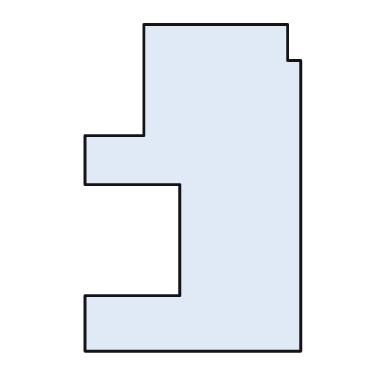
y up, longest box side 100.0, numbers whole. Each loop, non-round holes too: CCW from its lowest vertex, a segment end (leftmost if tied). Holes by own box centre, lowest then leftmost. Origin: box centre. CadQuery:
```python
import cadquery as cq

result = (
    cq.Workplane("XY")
    .moveTo(-33.0, -50.0)
    .lineTo(33.0, -50.0)
    .lineTo(33.0, 39.0)
    .lineTo(29.0, 39.0)
    .lineTo(29.0, 50.0)
    .lineTo(-15.0, 50.0)
    .lineTo(-15.0, 16.0)
    .lineTo(-33.0, 16.0)
    .lineTo(-33.0, 1.0)
    .lineTo(-4.0, 1.0)
    .lineTo(-4.0, -33.0)
    .lineTo(-33.0, -33.0)
    .close()
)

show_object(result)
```